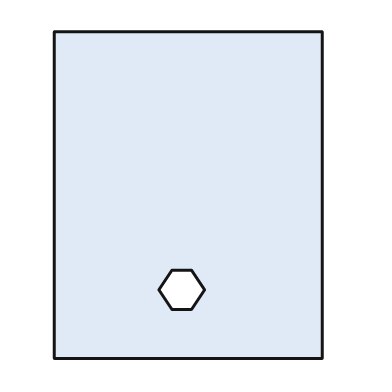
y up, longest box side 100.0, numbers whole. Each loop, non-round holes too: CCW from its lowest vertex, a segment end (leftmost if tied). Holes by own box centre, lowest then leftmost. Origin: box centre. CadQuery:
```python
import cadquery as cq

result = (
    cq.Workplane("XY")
    .moveTo(-41.0, -50.0)
    .lineTo(41.0, -50.0)
    .lineTo(41.0, 50.0)
    .lineTo(-41.0, 50.0)
    .close()
    .moveTo(-5.0, -35.0)
    .lineTo(1.0, -35.0)
    .lineTo(5.0, -29.0)
    .lineTo(1.0, -23.0)
    .lineTo(-5.0, -23.0)
    .lineTo(-9.0, -29.0)
    .close()
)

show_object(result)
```